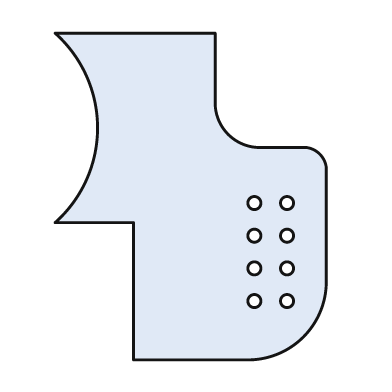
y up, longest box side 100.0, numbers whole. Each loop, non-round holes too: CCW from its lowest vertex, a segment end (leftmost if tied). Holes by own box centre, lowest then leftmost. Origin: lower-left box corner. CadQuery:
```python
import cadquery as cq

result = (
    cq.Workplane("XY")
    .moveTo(24.0, 0.0)
    .lineTo(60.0, 0.0)
    .threePointArc((76.0, 7.0), (83.0, 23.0))
    .lineTo(83.0, 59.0)
    .threePointArc((81.0, 63.0), (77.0, 65.0))
    .lineTo(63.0, 65.0)
    .threePointArc((53.0, 69.0), (49.0, 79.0))
    .lineTo(49.0, 100.0)
    .lineTo(0.0, 100.0)
    .threePointArc((13.0, 71.0), (0.0, 42.0))
    .lineTo(24.0, 42.0)
    .close()
    .moveTo(61.0, 18.0)
    .circle(2.0)
    .moveTo(71.0, 18.0)
    .circle(2.0)
    .moveTo(61.0, 28.0)
    .circle(2.0)
    .moveTo(71.0, 28.0)
    .circle(2.0)
    .moveTo(61.0, 38.0)
    .circle(2.0)
    .moveTo(71.0, 38.0)
    .circle(2.0)
    .moveTo(61.0, 48.0)
    .circle(2.0)
    .moveTo(71.0, 48.0)
    .circle(2.0)
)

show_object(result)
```